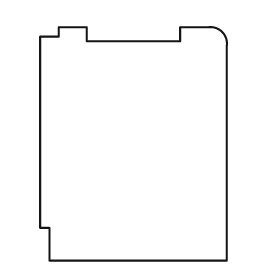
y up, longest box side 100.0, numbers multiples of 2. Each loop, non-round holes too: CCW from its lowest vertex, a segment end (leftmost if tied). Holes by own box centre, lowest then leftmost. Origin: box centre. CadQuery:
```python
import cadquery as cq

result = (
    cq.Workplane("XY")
    .moveTo(-36.0, -50.0)
    .lineTo(40.0, -50.0)
    .lineTo(40.0, 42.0)
    .threePointArc((38.0, 48.0), (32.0, 50.0))
    .lineTo(20.0, 50.0)
    .lineTo(20.0, 44.0)
    .lineTo(-20.0, 44.0)
    .lineTo(-20.0, 50.0)
    .lineTo(-32.0, 50.0)
    .lineTo(-32.0, 46.0)
    .lineTo(-40.0, 46.0)
    .lineTo(-40.0, -36.0)
    .lineTo(-36.0, -36.0)
    .close()
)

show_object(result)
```